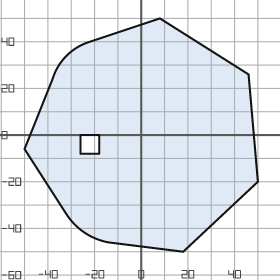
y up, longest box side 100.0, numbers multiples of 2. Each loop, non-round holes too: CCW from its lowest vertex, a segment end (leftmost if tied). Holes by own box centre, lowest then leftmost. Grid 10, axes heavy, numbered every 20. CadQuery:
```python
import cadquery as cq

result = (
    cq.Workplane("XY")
    .moveTo(18.0, -50.0)
    .lineTo(50.0, -20.0)
    .lineTo(46.0, 26.0)
    .lineTo(8.0, 50.0)
    .lineTo(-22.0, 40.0)
    .threePointArc((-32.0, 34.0), (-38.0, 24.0))
    .lineTo(-50.0, -6.0)
    .lineTo(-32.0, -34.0)
    .threePointArc((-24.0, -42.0), (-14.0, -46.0))
    .close()
    .moveTo(-26.0, -8.0)
    .lineTo(-18.0, -8.0)
    .lineTo(-18.0, 0.0)
    .lineTo(-26.0, 0.0)
    .close()
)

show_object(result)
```